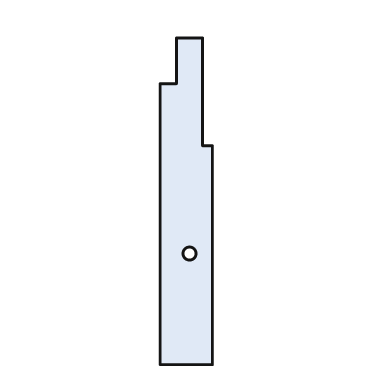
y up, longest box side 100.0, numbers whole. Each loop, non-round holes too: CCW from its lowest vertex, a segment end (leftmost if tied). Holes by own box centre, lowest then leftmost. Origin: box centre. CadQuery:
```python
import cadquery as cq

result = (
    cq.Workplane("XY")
    .moveTo(-8.0, -50.0)
    .lineTo(8.0, -50.0)
    .lineTo(8.0, 17.0)
    .lineTo(5.0, 17.0)
    .lineTo(5.0, 50.0)
    .lineTo(-3.0, 50.0)
    .lineTo(-3.0, 36.0)
    .lineTo(-8.0, 36.0)
    .close()
    .moveTo(1.0, -16.0)
    .circle(2.0)
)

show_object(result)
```